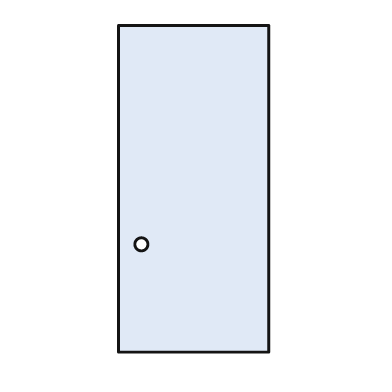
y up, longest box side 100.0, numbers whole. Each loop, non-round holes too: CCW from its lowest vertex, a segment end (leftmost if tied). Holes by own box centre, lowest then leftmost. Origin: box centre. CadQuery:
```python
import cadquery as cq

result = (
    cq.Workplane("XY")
    .moveTo(-23.0, -50.0)
    .lineTo(23.0, -50.0)
    .lineTo(23.0, 50.0)
    .lineTo(-23.0, 50.0)
    .close()
    .moveTo(-16.0, -17.0)
    .circle(2.0)
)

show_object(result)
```